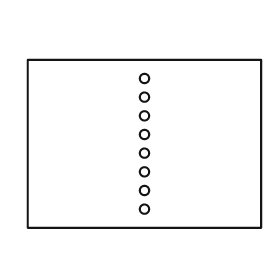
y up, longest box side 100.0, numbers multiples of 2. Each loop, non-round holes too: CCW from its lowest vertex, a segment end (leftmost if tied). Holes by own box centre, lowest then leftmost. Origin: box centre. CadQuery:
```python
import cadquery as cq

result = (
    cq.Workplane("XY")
    .moveTo(-50.0, -36.0)
    .lineTo(50.0, -36.0)
    .lineTo(50.0, 36.0)
    .lineTo(-50.0, 36.0)
    .close()
    .moveTo(0.0, -28.0)
    .circle(2.0)
    .moveTo(0.0, -20.0)
    .circle(2.0)
    .moveTo(0.0, -12.0)
    .circle(2.0)
    .moveTo(0.0, -4.0)
    .circle(2.0)
    .moveTo(0.0, 4.0)
    .circle(2.0)
    .moveTo(0.0, 12.0)
    .circle(2.0)
    .moveTo(0.0, 20.0)
    .circle(2.0)
    .moveTo(0.0, 28.0)
    .circle(2.0)
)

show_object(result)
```